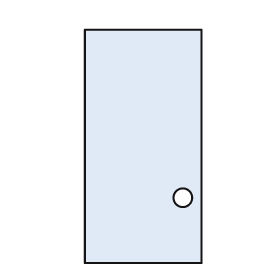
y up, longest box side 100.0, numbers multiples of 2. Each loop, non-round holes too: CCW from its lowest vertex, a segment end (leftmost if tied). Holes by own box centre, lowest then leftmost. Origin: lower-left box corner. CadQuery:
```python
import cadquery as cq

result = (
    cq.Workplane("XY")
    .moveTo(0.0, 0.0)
    .lineTo(50.0, 0.0)
    .lineTo(50.0, 100.0)
    .lineTo(0.0, 100.0)
    .close()
    .moveTo(42.0, 28.0)
    .circle(4.0)
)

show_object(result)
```